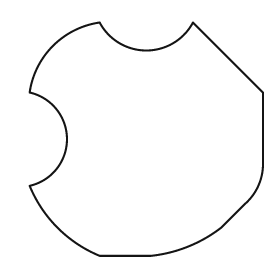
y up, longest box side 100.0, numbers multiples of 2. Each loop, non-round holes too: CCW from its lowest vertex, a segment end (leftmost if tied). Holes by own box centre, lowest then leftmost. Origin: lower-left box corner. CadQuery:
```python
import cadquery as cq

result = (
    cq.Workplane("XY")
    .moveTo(30.0, 0.0)
    .lineTo(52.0, 0.0)
    .threePointArc((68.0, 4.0), (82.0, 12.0))
    .lineTo(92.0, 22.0)
    .threePointArc((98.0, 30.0), (100.0, 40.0))
    .lineTo(100.0, 70.0)
    .lineTo(70.0, 100.0)
    .threePointArc((50.0, 88.0), (30.0, 100.0))
    .threePointArc((10.0, 90.0), (0.0, 70.0))
    .threePointArc((16.0, 50.0), (0.0, 30.0))
    .threePointArc((12.0, 12.0), (30.0, 0.0))
    .close()
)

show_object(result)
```